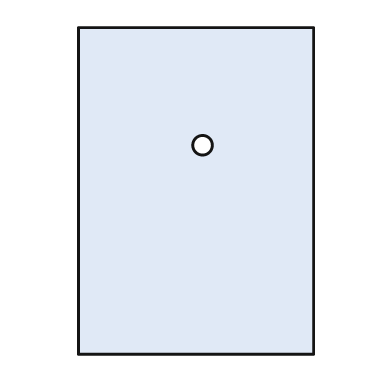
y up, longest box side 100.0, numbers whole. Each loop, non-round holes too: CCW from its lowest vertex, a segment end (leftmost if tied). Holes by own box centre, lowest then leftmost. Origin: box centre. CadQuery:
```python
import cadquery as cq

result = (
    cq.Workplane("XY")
    .moveTo(-36.0, -50.0)
    .lineTo(36.0, -50.0)
    .lineTo(36.0, 50.0)
    .lineTo(-36.0, 50.0)
    .close()
    .moveTo(2.0, 14.0)
    .circle(3.0)
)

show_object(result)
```